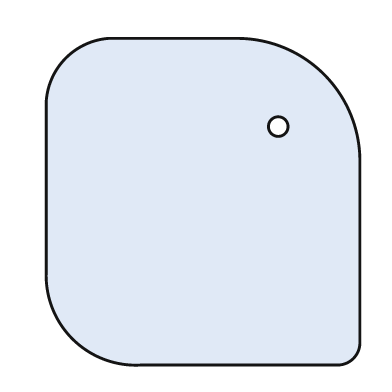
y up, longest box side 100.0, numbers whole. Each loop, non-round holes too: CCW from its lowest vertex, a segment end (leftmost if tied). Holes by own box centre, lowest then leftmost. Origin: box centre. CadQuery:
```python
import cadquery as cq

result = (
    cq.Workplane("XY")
    .moveTo(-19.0, -50.0)
    .lineTo(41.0, -50.0)
    .threePointArc((46.0, -48.0), (48.0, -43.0))
    .lineTo(48.0, 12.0)
    .threePointArc((37.0, 39.0), (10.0, 50.0))
    .lineTo(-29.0, 50.0)
    .threePointArc((-42.0, 44.0), (-48.0, 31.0))
    .lineTo(-48.0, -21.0)
    .threePointArc((-40.0, -42.0), (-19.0, -50.0))
    .close()
    .moveTo(23.0, 23.0)
    .circle(3.0)
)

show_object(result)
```